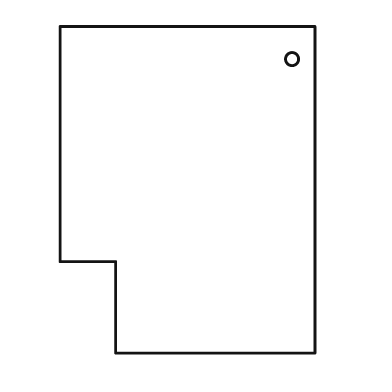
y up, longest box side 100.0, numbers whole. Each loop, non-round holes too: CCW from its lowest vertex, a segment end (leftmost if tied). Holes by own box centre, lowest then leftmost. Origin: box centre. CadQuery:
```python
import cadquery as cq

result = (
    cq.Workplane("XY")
    .moveTo(-22.0, -50.0)
    .lineTo(39.0, -50.0)
    .lineTo(39.0, 50.0)
    .lineTo(-39.0, 50.0)
    .lineTo(-39.0, -22.0)
    .lineTo(-22.0, -22.0)
    .close()
    .moveTo(32.0, 40.0)
    .circle(2.0)
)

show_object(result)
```